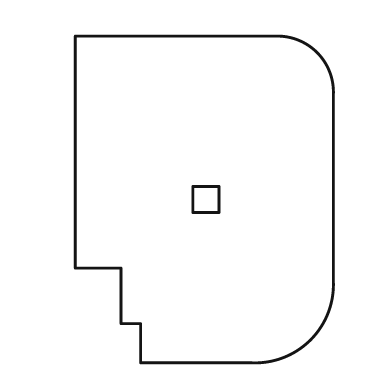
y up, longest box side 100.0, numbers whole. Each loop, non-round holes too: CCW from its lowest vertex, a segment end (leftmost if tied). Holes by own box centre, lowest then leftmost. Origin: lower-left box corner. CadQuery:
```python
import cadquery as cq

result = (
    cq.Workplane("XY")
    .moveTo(20.0, 0.0)
    .lineTo(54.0, 0.0)
    .threePointArc((72.0, 7.0), (79.0, 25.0))
    .lineTo(79.0, 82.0)
    .threePointArc((74.0, 95.0), (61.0, 100.0))
    .lineTo(0.0, 100.0)
    .lineTo(0.0, 29.0)
    .lineTo(14.0, 29.0)
    .lineTo(14.0, 12.0)
    .lineTo(20.0, 12.0)
    .close()
    .moveTo(36.0, 46.0)
    .lineTo(44.0, 46.0)
    .lineTo(44.0, 54.0)
    .lineTo(36.0, 54.0)
    .close()
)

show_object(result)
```